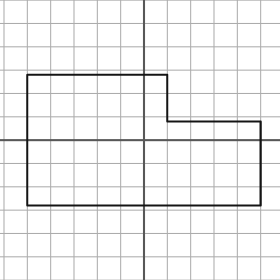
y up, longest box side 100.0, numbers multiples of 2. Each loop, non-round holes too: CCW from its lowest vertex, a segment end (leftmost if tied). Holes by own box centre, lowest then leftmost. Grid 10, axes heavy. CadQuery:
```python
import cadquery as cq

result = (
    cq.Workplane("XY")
    .moveTo(-50.0, -28.0)
    .lineTo(50.0, -28.0)
    .lineTo(50.0, 8.0)
    .lineTo(10.0, 8.0)
    .lineTo(10.0, 28.0)
    .lineTo(-50.0, 28.0)
    .close()
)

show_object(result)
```